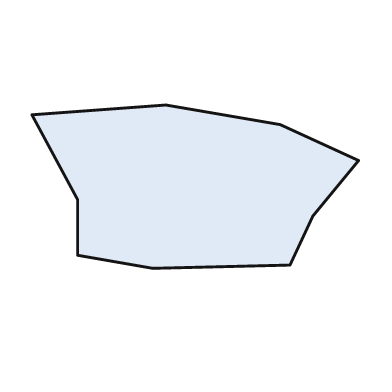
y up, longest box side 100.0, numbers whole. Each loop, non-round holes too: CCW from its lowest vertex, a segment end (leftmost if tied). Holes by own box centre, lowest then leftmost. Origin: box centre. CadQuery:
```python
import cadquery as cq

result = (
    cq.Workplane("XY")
    .moveTo(-13.0, -25.0)
    .lineTo(29.0, -24.0)
    .lineTo(36.0, -9.0)
    .lineTo(50.0, 8.0)
    .lineTo(26.0, 19.0)
    .lineTo(-9.0, 25.0)
    .lineTo(-50.0, 22.0)
    .lineTo(-36.0, -4.0)
    .lineTo(-36.0, -21.0)
    .close()
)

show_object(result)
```